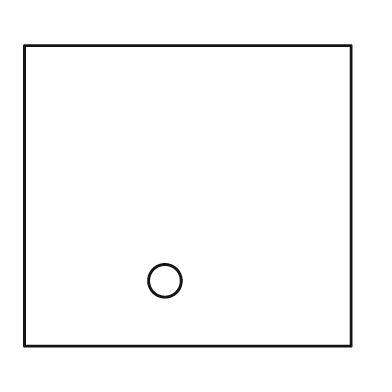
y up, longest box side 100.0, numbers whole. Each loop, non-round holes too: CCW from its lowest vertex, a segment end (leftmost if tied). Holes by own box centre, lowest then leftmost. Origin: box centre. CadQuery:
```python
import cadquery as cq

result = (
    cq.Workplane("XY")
    .moveTo(-50.0, -46.0)
    .lineTo(50.0, -46.0)
    .lineTo(50.0, 46.0)
    .lineTo(-50.0, 46.0)
    .close()
    .moveTo(-7.0, -26.0)
    .circle(5.0)
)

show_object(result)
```